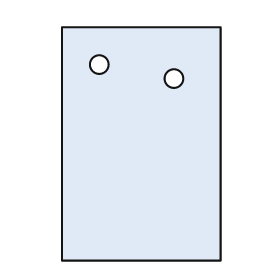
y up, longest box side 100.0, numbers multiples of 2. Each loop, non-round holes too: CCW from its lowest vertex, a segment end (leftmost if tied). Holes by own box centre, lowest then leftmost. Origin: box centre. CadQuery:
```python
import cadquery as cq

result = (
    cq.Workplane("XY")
    .moveTo(-34.0, -50.0)
    .lineTo(34.0, -50.0)
    .lineTo(34.0, 50.0)
    .lineTo(-34.0, 50.0)
    .close()
    .moveTo(14.0, 28.0)
    .circle(4.0)
    .moveTo(-18.0, 34.0)
    .circle(4.0)
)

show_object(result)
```